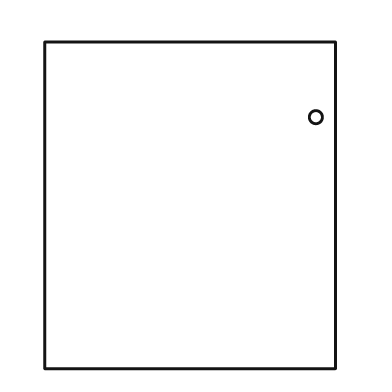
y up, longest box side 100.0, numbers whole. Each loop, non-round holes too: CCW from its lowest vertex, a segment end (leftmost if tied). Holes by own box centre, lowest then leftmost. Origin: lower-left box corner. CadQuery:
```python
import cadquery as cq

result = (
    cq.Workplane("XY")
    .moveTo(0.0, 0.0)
    .lineTo(89.0, 0.0)
    .lineTo(89.0, 100.0)
    .lineTo(0.0, 100.0)
    .close()
    .moveTo(83.0, 77.0)
    .circle(2.0)
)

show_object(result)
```